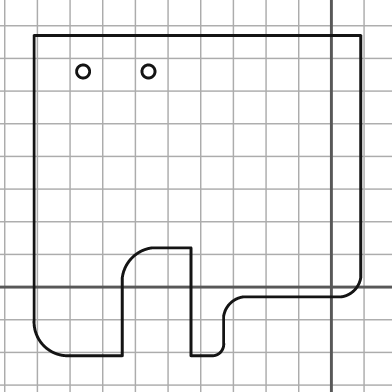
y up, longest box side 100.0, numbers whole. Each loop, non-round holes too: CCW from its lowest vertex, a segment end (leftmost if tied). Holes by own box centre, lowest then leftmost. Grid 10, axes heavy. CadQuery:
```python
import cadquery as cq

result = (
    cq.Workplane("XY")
    .moveTo(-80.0, -21.0)
    .lineTo(-64.0, -21.0)
    .lineTo(-64.0, 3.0)
    .threePointArc((-61.0, 9.0), (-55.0, 12.0))
    .lineTo(-43.0, 12.0)
    .lineTo(-43.0, -21.0)
    .lineTo(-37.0, -21.0)
    .threePointArc((-34.0, -20.0), (-33.0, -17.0))
    .lineTo(-33.0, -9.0)
    .threePointArc((-31.0, -5.0), (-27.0, -3.0))
    .lineTo(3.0, -3.0)
    .threePointArc((7.0, -1.0), (9.0, 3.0))
    .lineTo(9.0, 77.0)
    .lineTo(-91.0, 77.0)
    .lineTo(-91.0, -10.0)
    .threePointArc((-88.0, -18.0), (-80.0, -21.0))
    .close()
    .moveTo(-76.0, 66.0)
    .circle(2.0)
    .moveTo(-56.0, 66.0)
    .circle(2.0)
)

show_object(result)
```